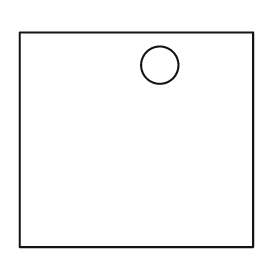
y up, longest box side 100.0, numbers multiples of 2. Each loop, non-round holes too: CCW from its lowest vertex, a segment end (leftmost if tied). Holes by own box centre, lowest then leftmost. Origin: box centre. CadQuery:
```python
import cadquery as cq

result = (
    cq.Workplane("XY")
    .moveTo(-50.0, -46.0)
    .lineTo(50.0, -46.0)
    .lineTo(50.0, 46.0)
    .lineTo(-50.0, 46.0)
    .close()
    .moveTo(10.0, 32.0)
    .circle(8.0)
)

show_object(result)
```